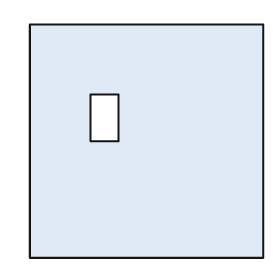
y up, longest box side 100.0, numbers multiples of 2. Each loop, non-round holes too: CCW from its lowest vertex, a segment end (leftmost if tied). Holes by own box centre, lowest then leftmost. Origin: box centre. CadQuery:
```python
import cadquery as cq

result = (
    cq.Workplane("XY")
    .moveTo(-50.0, -50.0)
    .lineTo(50.0, -50.0)
    .lineTo(50.0, 50.0)
    .lineTo(-50.0, 50.0)
    .close()
    .moveTo(-24.0, 0.0)
    .lineTo(-12.0, 0.0)
    .lineTo(-12.0, 20.0)
    .lineTo(-24.0, 20.0)
    .close()
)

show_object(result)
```